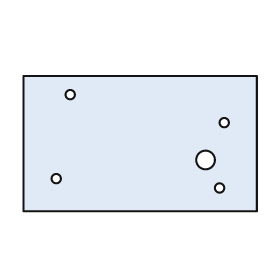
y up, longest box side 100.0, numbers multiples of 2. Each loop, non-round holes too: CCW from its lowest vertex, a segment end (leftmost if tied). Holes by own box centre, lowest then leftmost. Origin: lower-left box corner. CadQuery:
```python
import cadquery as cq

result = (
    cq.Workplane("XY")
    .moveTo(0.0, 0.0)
    .lineTo(100.0, 0.0)
    .lineTo(100.0, 58.0)
    .lineTo(0.0, 58.0)
    .close()
    .moveTo(84.0, 10.0)
    .circle(2.0)
    .moveTo(14.0, 14.0)
    .circle(2.0)
    .moveTo(78.0, 22.0)
    .circle(4.0)
    .moveTo(86.0, 38.0)
    .circle(2.0)
    .moveTo(20.0, 50.0)
    .circle(2.0)
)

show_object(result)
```